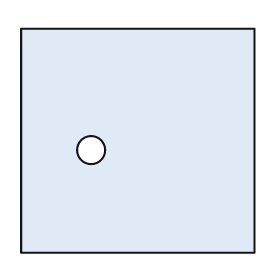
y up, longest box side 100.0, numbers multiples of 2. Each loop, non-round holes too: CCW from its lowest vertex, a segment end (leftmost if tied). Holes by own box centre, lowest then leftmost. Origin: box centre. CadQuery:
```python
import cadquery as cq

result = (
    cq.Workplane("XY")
    .moveTo(-50.0, -48.0)
    .lineTo(50.0, -48.0)
    .lineTo(50.0, 48.0)
    .lineTo(-50.0, 48.0)
    .close()
    .moveTo(-20.0, -4.0)
    .circle(6.0)
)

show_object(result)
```